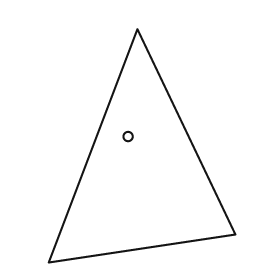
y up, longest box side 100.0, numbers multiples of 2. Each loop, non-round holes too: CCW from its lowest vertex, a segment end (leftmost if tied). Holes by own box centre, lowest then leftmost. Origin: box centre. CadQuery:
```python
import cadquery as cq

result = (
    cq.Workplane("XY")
    .moveTo(-40.0, -50.0)
    .lineTo(40.0, -38.0)
    .lineTo(-2.0, 50.0)
    .close()
    .moveTo(-6.0, 4.0)
    .circle(2.0)
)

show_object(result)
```